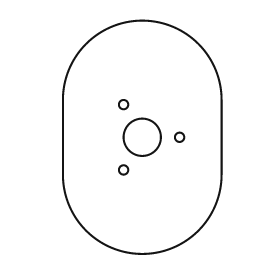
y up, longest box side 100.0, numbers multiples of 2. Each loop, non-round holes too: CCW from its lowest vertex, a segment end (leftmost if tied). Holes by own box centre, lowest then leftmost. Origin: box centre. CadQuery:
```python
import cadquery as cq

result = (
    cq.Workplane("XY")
    .moveTo(-34.0, -16.0)
    .threePointArc((0.0, -50.0), (34.0, -16.0))
    .lineTo(34.0, 16.0)
    .threePointArc((0.0, 50.0), (-34.0, 16.0))
    .close()
    .moveTo(-8.0, -14.0)
    .circle(2.0)
    .moveTo(0.0, 0.0)
    .circle(8.0)
    .moveTo(16.0, 0.0)
    .circle(2.0)
    .moveTo(-8.0, 14.0)
    .circle(2.0)
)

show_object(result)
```